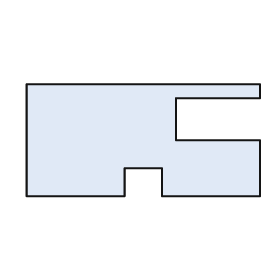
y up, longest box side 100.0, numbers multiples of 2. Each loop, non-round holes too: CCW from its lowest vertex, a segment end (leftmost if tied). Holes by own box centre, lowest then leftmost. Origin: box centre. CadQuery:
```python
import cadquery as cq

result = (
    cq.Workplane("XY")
    .moveTo(-50.0, -24.0)
    .lineTo(-8.0, -24.0)
    .lineTo(-8.0, -12.0)
    .lineTo(8.0, -12.0)
    .lineTo(8.0, -24.0)
    .lineTo(50.0, -24.0)
    .lineTo(50.0, 0.0)
    .lineTo(14.0, 0.0)
    .lineTo(14.0, 18.0)
    .lineTo(50.0, 18.0)
    .lineTo(50.0, 24.0)
    .lineTo(-50.0, 24.0)
    .close()
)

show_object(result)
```